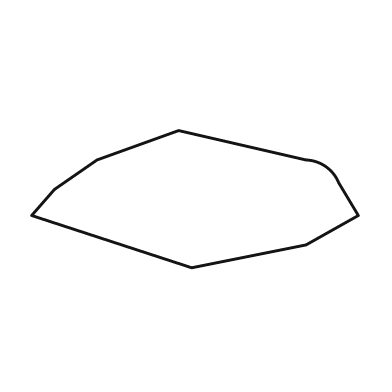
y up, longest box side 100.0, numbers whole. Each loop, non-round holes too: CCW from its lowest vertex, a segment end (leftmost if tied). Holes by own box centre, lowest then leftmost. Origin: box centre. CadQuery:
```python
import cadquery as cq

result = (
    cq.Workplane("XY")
    .moveTo(-1.0, -21.0)
    .lineTo(34.0, -14.0)
    .lineTo(50.0, -5.0)
    .lineTo(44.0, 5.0)
    .threePointArc((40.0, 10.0), (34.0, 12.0))
    .lineTo(-5.0, 21.0)
    .lineTo(-30.0, 12.0)
    .lineTo(-43.0, 3.0)
    .lineTo(-50.0, -5.0)
    .close()
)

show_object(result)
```